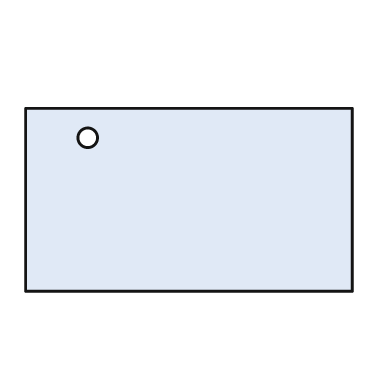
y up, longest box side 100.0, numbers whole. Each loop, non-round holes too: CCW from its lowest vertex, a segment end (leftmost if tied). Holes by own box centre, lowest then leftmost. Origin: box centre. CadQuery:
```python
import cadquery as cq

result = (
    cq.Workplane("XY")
    .moveTo(-50.0, -28.0)
    .lineTo(50.0, -28.0)
    .lineTo(50.0, 28.0)
    .lineTo(-50.0, 28.0)
    .close()
    .moveTo(-31.0, 19.0)
    .circle(3.0)
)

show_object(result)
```